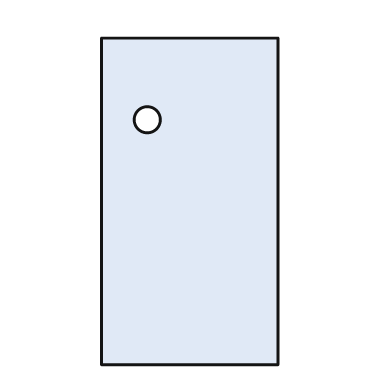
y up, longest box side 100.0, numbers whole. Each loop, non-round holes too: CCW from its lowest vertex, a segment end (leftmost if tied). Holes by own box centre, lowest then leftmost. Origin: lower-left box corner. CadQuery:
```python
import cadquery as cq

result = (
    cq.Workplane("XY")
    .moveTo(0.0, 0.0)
    .lineTo(54.0, 0.0)
    .lineTo(54.0, 100.0)
    .lineTo(0.0, 100.0)
    .close()
    .moveTo(14.0, 75.0)
    .circle(4.0)
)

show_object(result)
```